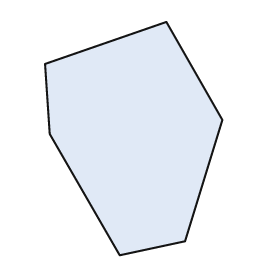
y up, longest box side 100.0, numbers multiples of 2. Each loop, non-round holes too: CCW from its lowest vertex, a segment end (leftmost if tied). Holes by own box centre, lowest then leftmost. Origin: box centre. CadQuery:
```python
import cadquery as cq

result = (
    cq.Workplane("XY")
    .moveTo(-6.0, -50.0)
    .lineTo(22.0, -44.0)
    .lineTo(38.0, 8.0)
    .lineTo(14.0, 50.0)
    .lineTo(-38.0, 32.0)
    .lineTo(-36.0, 2.0)
    .close()
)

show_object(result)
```